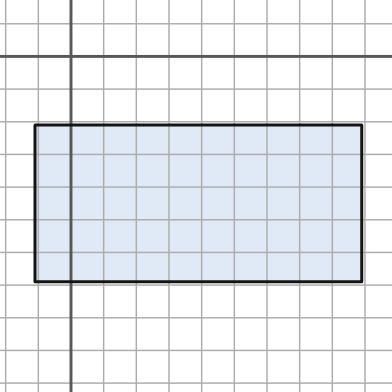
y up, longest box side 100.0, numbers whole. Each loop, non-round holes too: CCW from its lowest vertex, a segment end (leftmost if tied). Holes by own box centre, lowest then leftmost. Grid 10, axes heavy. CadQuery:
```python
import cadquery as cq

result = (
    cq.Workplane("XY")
    .moveTo(-11.0, -69.0)
    .lineTo(89.0, -69.0)
    .lineTo(89.0, -21.0)
    .lineTo(-11.0, -21.0)
    .close()
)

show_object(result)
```